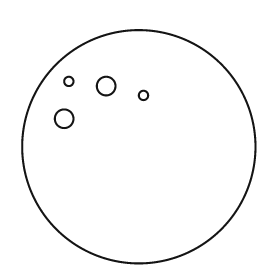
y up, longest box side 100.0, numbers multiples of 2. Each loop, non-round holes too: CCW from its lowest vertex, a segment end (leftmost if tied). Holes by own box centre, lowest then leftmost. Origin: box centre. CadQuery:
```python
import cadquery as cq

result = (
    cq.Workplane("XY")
    .moveTo(0.0, 0.0)
    .circle(50.0)
    .moveTo(-32.0, 12.0)
    .circle(4.0)
    .moveTo(2.0, 22.0)
    .circle(2.0)
    .moveTo(-14.0, 26.0)
    .circle(4.0)
    .moveTo(-30.0, 28.0)
    .circle(2.0)
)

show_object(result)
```